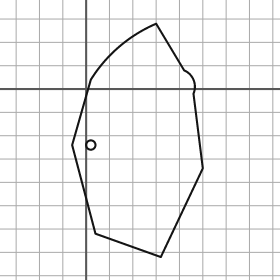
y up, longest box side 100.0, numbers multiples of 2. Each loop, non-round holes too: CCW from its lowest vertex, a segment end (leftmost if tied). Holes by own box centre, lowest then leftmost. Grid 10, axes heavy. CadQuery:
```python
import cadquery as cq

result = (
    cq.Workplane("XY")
    .moveTo(32.0, -72.0)
    .lineTo(50.0, -34.0)
    .lineTo(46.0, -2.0)
    .threePointArc((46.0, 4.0), (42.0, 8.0))
    .lineTo(30.0, 28.0)
    .threePointArc((14.0, 18.0), (2.0, 4.0))
    .lineTo(-6.0, -24.0)
    .lineTo(4.0, -62.0)
    .close()
    .moveTo(2.0, -24.0)
    .circle(2.0)
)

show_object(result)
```